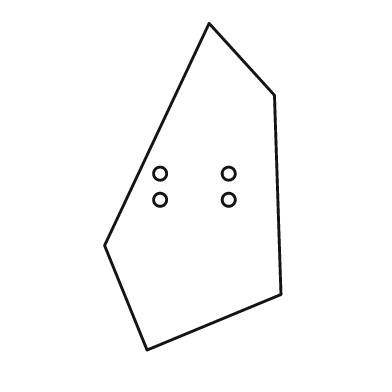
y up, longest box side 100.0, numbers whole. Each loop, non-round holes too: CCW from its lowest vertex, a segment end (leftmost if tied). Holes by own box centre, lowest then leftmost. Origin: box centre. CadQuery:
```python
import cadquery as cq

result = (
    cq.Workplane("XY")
    .moveTo(-14.0, -50.0)
    .lineTo(27.0, -33.0)
    .lineTo(25.0, 28.0)
    .lineTo(5.0, 50.0)
    .lineTo(-27.0, -18.0)
    .close()
    .moveTo(-10.0, -4.0)
    .circle(2.0)
    .moveTo(11.0, -4.0)
    .circle(2.0)
    .moveTo(-10.0, 4.0)
    .circle(2.0)
    .moveTo(11.0, 4.0)
    .circle(2.0)
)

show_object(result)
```